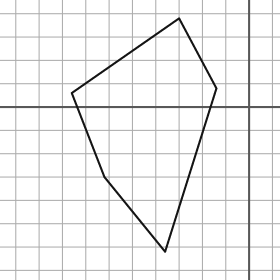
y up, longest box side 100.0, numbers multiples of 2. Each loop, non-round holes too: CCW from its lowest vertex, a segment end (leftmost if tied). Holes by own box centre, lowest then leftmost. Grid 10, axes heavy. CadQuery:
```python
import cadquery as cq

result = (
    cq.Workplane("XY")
    .moveTo(-36.0, -62.0)
    .lineTo(-14.0, 8.0)
    .lineTo(-30.0, 38.0)
    .lineTo(-76.0, 6.0)
    .lineTo(-62.0, -30.0)
    .close()
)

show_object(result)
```